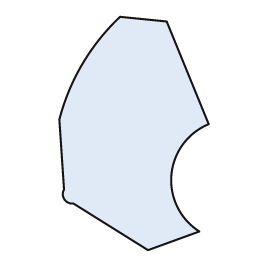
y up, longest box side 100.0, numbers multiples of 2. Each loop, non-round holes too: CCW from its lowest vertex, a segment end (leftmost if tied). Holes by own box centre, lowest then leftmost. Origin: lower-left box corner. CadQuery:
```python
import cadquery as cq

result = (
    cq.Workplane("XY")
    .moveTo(38.0, 0.0)
    .lineTo(60.0, 8.0)
    .threePointArc((48.0, 32.0), (64.0, 54.0))
    .lineTo(46.0, 98.0)
    .lineTo(26.0, 100.0)
    .threePointArc((10.0, 80.0), (0.0, 56.0))
    .lineTo(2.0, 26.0)
    .threePointArc((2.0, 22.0), (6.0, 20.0))
    .close()
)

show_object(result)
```